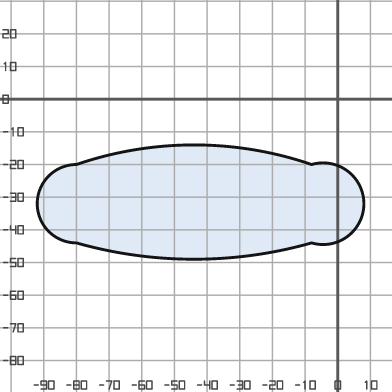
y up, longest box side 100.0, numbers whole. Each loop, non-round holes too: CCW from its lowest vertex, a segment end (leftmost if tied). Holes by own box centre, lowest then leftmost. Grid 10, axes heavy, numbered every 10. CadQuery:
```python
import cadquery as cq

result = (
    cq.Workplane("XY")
    .moveTo(-80.0, -44.0)
    .threePointArc((-44.0, -49.0), (-8.0, -44.0))
    .threePointArc((8.0, -32.0), (-8.0, -20.0))
    .threePointArc((-44.0, -14.0), (-80.0, -20.0))
    .threePointArc((-92.0, -32.0), (-80.0, -44.0))
    .close()
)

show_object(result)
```